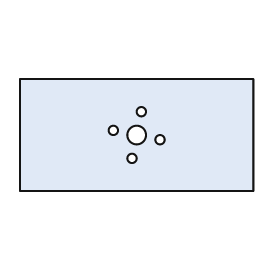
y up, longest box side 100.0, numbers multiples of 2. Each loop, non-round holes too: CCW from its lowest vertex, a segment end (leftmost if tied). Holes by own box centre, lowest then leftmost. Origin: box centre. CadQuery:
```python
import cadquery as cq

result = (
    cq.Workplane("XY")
    .moveTo(-50.0, -24.0)
    .lineTo(50.0, -24.0)
    .lineTo(50.0, 24.0)
    .lineTo(-50.0, 24.0)
    .close()
    .moveTo(-2.0, -10.0)
    .circle(2.0)
    .moveTo(10.0, -2.0)
    .circle(2.0)
    .moveTo(0.0, 0.0)
    .circle(4.0)
    .moveTo(-10.0, 2.0)
    .circle(2.0)
    .moveTo(2.0, 10.0)
    .circle(2.0)
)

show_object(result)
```